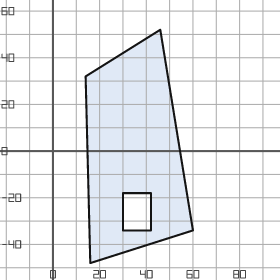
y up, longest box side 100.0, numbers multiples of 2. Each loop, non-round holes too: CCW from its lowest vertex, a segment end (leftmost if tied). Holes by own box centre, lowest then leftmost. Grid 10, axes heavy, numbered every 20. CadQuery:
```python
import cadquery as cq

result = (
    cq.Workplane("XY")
    .moveTo(16.0, -48.0)
    .lineTo(60.0, -34.0)
    .lineTo(46.0, 52.0)
    .lineTo(14.0, 32.0)
    .close()
    .moveTo(30.0, -34.0)
    .lineTo(42.0, -34.0)
    .lineTo(42.0, -18.0)
    .lineTo(30.0, -18.0)
    .close()
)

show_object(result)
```